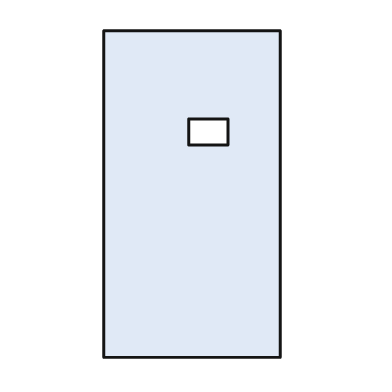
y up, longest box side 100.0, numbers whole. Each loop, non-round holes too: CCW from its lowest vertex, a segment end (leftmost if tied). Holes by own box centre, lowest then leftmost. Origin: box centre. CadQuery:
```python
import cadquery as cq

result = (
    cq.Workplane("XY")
    .moveTo(-27.0, -50.0)
    .lineTo(27.0, -50.0)
    .lineTo(27.0, 50.0)
    .lineTo(-27.0, 50.0)
    .close()
    .moveTo(-1.0, 15.0)
    .lineTo(11.0, 15.0)
    .lineTo(11.0, 23.0)
    .lineTo(-1.0, 23.0)
    .close()
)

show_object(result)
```